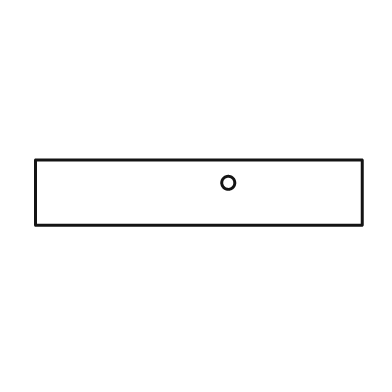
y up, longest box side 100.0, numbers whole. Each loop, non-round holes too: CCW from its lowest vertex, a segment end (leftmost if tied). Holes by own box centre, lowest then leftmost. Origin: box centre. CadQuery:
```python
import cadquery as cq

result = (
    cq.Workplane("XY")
    .moveTo(-50.0, -10.0)
    .lineTo(50.0, -10.0)
    .lineTo(50.0, 10.0)
    .lineTo(-50.0, 10.0)
    .close()
    .moveTo(9.0, 3.0)
    .circle(2.0)
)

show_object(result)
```